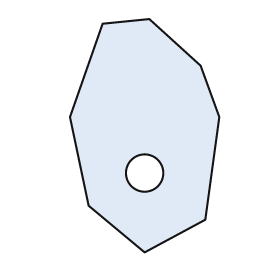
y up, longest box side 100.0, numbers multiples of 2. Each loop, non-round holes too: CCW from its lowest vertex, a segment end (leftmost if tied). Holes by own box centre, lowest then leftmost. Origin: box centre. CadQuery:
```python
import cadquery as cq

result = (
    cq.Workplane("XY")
    .moveTo(0.0, -50.0)
    .lineTo(26.0, -36.0)
    .lineTo(32.0, 8.0)
    .lineTo(24.0, 30.0)
    .lineTo(2.0, 50.0)
    .lineTo(-18.0, 48.0)
    .lineTo(-32.0, 8.0)
    .lineTo(-24.0, -30.0)
    .close()
    .moveTo(0.0, -16.0)
    .circle(8.0)
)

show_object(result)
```